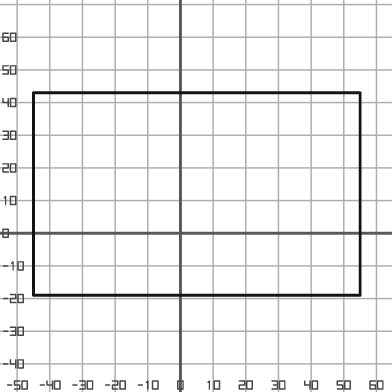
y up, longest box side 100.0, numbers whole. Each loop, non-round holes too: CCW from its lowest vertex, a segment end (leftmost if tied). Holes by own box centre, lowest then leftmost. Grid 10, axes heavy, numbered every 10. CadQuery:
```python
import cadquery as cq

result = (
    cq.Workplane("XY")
    .moveTo(-45.0, -19.0)
    .lineTo(55.0, -19.0)
    .lineTo(55.0, 43.0)
    .lineTo(-45.0, 43.0)
    .close()
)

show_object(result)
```